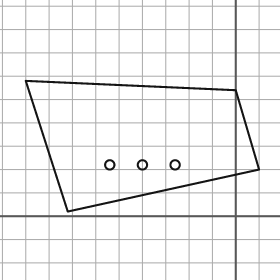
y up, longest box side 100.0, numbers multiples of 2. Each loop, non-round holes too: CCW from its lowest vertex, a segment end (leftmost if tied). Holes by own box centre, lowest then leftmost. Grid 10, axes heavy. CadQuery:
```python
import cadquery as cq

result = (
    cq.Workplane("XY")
    .moveTo(-72.0, 2.0)
    .lineTo(10.0, 20.0)
    .lineTo(0.0, 54.0)
    .lineTo(-90.0, 58.0)
    .close()
    .moveTo(-54.0, 22.0)
    .circle(2.0)
    .moveTo(-40.0, 22.0)
    .circle(2.0)
    .moveTo(-26.0, 22.0)
    .circle(2.0)
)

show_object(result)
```